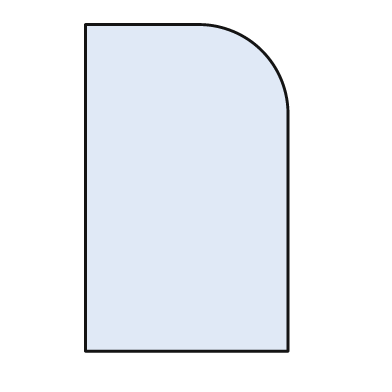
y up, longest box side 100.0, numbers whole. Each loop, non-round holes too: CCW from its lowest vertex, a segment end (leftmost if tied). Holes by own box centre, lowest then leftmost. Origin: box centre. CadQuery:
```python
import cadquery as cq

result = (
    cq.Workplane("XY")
    .moveTo(-31.0, -50.0)
    .lineTo(31.0, -50.0)
    .lineTo(31.0, 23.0)
    .threePointArc((23.0, 42.0), (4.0, 50.0))
    .lineTo(-31.0, 50.0)
    .close()
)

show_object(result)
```